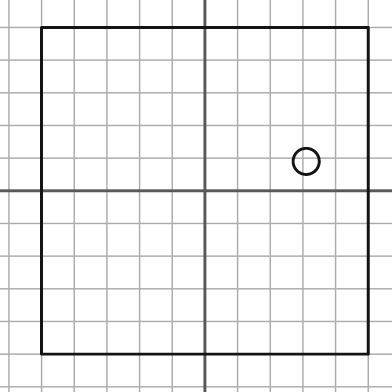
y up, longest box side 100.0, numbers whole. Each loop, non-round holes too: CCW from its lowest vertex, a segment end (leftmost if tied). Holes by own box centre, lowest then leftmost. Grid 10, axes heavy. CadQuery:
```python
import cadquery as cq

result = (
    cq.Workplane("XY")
    .moveTo(-50.0, -50.0)
    .lineTo(50.0, -50.0)
    .lineTo(50.0, 50.0)
    .lineTo(-50.0, 50.0)
    .close()
    .moveTo(31.0, 9.0)
    .circle(4.0)
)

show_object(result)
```